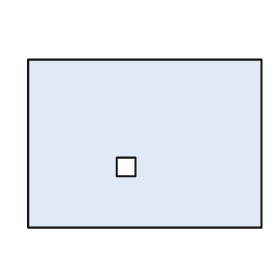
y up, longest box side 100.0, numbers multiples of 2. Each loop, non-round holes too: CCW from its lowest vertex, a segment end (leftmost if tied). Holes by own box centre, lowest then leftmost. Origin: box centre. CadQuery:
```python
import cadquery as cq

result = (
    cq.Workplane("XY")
    .moveTo(-50.0, -36.0)
    .lineTo(50.0, -36.0)
    .lineTo(50.0, 36.0)
    .lineTo(-50.0, 36.0)
    .close()
    .moveTo(-12.0, -14.0)
    .lineTo(-4.0, -14.0)
    .lineTo(-4.0, -6.0)
    .lineTo(-12.0, -6.0)
    .close()
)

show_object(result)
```